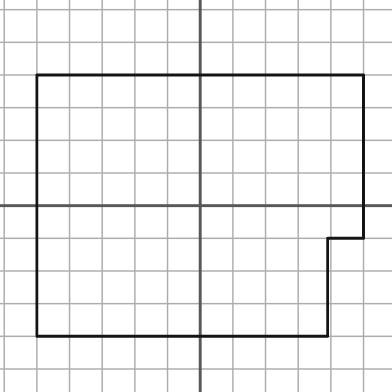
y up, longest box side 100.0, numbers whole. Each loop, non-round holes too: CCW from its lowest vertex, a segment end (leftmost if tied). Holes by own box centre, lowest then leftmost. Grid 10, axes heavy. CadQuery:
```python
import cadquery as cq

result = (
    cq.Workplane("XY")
    .moveTo(-50.0, -40.0)
    .lineTo(39.0, -40.0)
    .lineTo(39.0, -10.0)
    .lineTo(50.0, -10.0)
    .lineTo(50.0, 40.0)
    .lineTo(-50.0, 40.0)
    .close()
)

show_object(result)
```